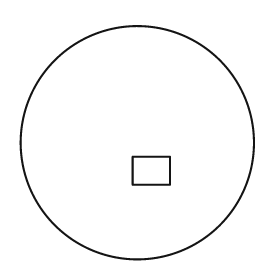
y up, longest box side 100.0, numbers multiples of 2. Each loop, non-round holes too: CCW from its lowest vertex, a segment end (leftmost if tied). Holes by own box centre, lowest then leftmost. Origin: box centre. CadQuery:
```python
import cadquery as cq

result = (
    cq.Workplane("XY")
    .moveTo(0.0, 0.0)
    .circle(50.0)
    .moveTo(-2.0, -18.0)
    .lineTo(14.0, -18.0)
    .lineTo(14.0, -6.0)
    .lineTo(-2.0, -6.0)
    .close()
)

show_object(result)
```